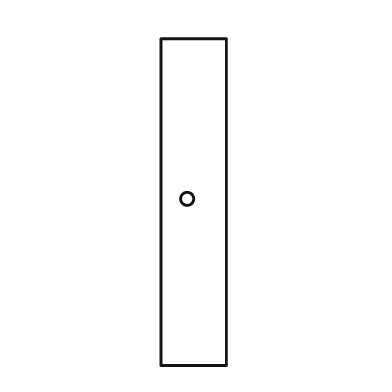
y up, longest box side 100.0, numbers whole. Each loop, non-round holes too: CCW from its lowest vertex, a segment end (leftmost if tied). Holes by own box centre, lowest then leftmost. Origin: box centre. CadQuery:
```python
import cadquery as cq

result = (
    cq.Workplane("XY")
    .moveTo(-10.0, -50.0)
    .lineTo(10.0, -50.0)
    .lineTo(10.0, 50.0)
    .lineTo(-10.0, 50.0)
    .close()
    .moveTo(-2.0, 1.0)
    .circle(2.0)
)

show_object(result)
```